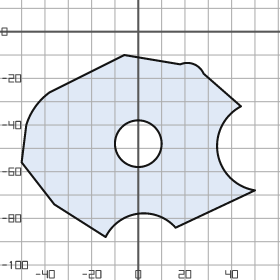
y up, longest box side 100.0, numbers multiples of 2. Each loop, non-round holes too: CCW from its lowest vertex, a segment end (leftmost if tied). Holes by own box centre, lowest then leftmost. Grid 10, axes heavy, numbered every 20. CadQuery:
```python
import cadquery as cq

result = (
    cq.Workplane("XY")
    .moveTo(-14.0, -88.0)
    .threePointArc((0.0, -78.0), (16.0, -84.0))
    .lineTo(50.0, -68.0)
    .threePointArc((34.0, -52.0), (44.0, -32.0))
    .lineTo(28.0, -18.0)
    .threePointArc((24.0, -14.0), (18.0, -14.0))
    .lineTo(-6.0, -10.0)
    .lineTo(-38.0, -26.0)
    .threePointArc((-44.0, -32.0), (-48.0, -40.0))
    .lineTo(-50.0, -56.0)
    .lineTo(-36.0, -74.0)
    .close()
    .moveTo(0.0, -48.0)
    .circle(10.0)
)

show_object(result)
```